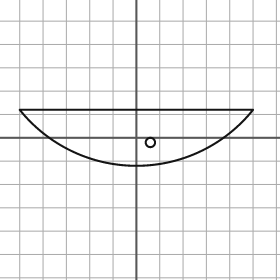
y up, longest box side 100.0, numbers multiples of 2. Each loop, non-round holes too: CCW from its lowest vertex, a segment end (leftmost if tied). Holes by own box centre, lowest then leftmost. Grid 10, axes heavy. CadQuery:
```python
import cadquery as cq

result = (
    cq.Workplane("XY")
    .moveTo(-50.0, 12.0)
    .threePointArc((0.0, -12.0), (50.0, 12.0))
    .close()
    .moveTo(6.0, -2.0)
    .circle(2.0)
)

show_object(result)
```